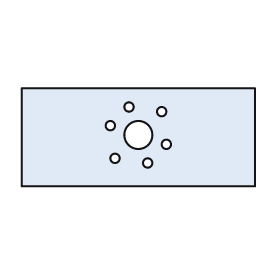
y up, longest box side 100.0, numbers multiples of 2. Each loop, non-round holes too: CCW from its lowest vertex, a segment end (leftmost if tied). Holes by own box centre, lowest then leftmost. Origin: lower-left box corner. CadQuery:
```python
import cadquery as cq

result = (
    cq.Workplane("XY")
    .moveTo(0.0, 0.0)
    .lineTo(100.0, 0.0)
    .lineTo(100.0, 42.0)
    .lineTo(0.0, 42.0)
    .close()
    .moveTo(54.0, 10.0)
    .circle(2.0)
    .moveTo(40.0, 12.0)
    .circle(2.0)
    .moveTo(62.0, 18.0)
    .circle(2.0)
    .moveTo(50.0, 22.0)
    .circle(6.0)
    .moveTo(38.0, 26.0)
    .circle(2.0)
    .moveTo(60.0, 32.0)
    .circle(2.0)
    .moveTo(46.0, 34.0)
    .circle(2.0)
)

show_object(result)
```